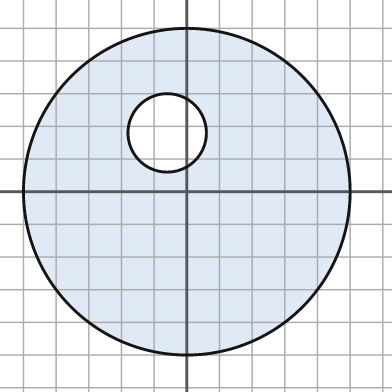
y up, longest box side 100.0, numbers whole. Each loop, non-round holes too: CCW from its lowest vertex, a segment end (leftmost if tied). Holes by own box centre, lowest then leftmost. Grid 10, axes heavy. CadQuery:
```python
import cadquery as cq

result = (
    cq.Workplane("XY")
    .moveTo(0.0, 0.0)
    .circle(50.0)
    .moveTo(-6.0, 18.0)
    .circle(12.0)
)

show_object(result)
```